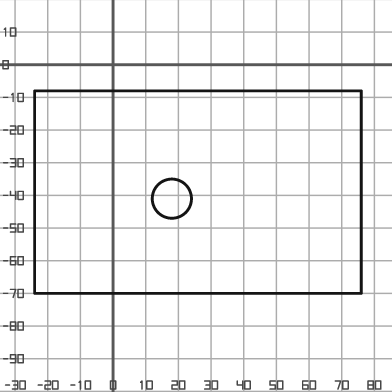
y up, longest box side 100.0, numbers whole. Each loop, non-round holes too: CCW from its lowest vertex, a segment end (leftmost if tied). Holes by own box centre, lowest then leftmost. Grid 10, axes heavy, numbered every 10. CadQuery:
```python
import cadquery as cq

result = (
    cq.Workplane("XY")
    .moveTo(-24.0, -70.0)
    .lineTo(76.0, -70.0)
    .lineTo(76.0, -8.0)
    .lineTo(-24.0, -8.0)
    .close()
    .moveTo(18.0, -41.0)
    .circle(6.0)
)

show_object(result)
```